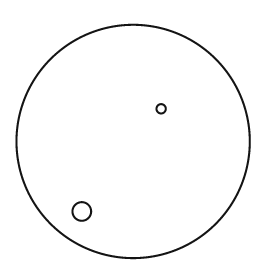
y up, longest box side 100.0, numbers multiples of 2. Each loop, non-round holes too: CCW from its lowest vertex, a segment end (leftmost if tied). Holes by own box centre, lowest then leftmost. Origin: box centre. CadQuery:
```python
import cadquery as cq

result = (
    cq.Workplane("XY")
    .moveTo(0.0, 0.0)
    .circle(50.0)
    .moveTo(-22.0, -30.0)
    .circle(4.0)
    .moveTo(12.0, 14.0)
    .circle(2.0)
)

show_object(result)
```